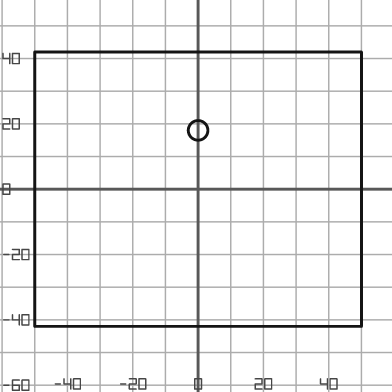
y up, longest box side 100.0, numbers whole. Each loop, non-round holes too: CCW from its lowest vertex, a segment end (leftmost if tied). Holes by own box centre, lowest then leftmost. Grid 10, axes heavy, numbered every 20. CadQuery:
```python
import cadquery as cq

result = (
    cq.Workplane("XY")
    .moveTo(-50.0, -42.0)
    .lineTo(50.0, -42.0)
    .lineTo(50.0, 42.0)
    .lineTo(-50.0, 42.0)
    .close()
    .moveTo(0.0, 18.0)
    .circle(3.0)
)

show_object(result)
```